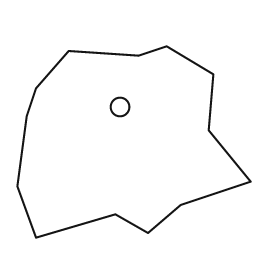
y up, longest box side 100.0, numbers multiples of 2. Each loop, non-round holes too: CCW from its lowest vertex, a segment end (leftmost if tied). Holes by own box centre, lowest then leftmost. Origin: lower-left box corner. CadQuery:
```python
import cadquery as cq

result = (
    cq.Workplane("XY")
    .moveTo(8.0, 0.0)
    .lineTo(42.0, 10.0)
    .lineTo(56.0, 2.0)
    .lineTo(70.0, 14.0)
    .lineTo(100.0, 24.0)
    .lineTo(82.0, 46.0)
    .lineTo(84.0, 70.0)
    .lineTo(64.0, 82.0)
    .lineTo(52.0, 78.0)
    .lineTo(22.0, 80.0)
    .lineTo(8.0, 64.0)
    .lineTo(4.0, 52.0)
    .lineTo(0.0, 22.0)
    .close()
    .moveTo(44.0, 56.0)
    .circle(4.0)
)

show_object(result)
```